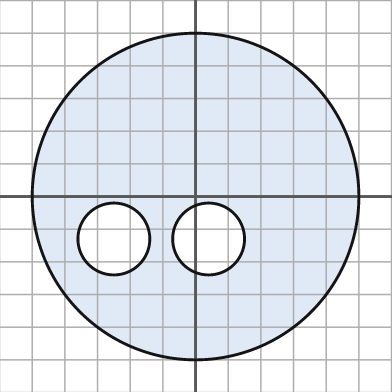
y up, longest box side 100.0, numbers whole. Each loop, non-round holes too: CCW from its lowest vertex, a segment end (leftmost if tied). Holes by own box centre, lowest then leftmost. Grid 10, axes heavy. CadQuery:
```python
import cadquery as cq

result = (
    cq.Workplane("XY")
    .moveTo(0.0, 0.0)
    .circle(50.0)
    .moveTo(-25.0, -13.0)
    .circle(11.0)
    .moveTo(4.0, -13.0)
    .circle(11.0)
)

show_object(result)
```